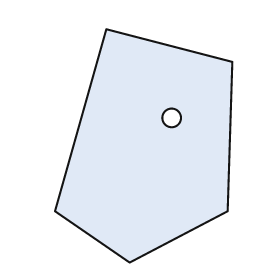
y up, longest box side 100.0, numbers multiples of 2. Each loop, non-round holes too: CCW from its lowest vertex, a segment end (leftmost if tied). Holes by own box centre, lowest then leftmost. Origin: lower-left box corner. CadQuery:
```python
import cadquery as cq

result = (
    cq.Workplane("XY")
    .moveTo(32.0, 0.0)
    .lineTo(74.0, 22.0)
    .lineTo(76.0, 86.0)
    .lineTo(22.0, 100.0)
    .lineTo(0.0, 22.0)
    .close()
    .moveTo(50.0, 62.0)
    .circle(4.0)
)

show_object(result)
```